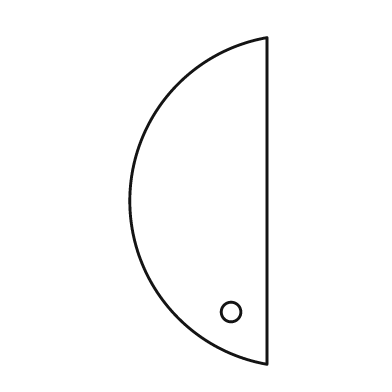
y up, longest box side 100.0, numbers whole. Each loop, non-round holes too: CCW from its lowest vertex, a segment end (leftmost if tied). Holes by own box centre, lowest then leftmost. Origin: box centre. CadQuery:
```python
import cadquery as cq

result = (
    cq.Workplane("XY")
    .moveTo(21.0, -50.0)
    .lineTo(21.0, 50.0)
    .threePointArc((-21.0, 0.0), (21.0, -50.0))
    .close()
    .moveTo(10.0, -34.0)
    .circle(3.0)
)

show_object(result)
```